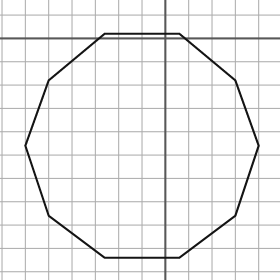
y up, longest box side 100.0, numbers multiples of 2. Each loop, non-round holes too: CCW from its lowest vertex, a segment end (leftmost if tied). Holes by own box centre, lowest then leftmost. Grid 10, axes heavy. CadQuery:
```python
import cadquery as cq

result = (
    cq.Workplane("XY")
    .moveTo(-26.0, -94.0)
    .lineTo(6.0, -94.0)
    .lineTo(30.0, -76.0)
    .lineTo(40.0, -46.0)
    .lineTo(30.0, -18.0)
    .lineTo(6.0, 2.0)
    .lineTo(-26.0, 2.0)
    .lineTo(-50.0, -18.0)
    .lineTo(-60.0, -46.0)
    .lineTo(-50.0, -76.0)
    .close()
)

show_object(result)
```